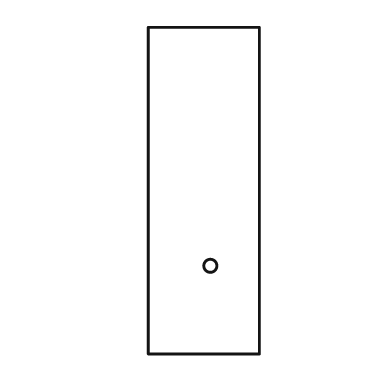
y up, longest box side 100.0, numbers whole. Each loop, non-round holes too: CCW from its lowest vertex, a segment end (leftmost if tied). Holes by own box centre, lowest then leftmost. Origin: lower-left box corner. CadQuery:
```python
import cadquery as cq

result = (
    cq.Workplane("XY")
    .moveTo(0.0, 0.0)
    .lineTo(34.0, 0.0)
    .lineTo(34.0, 100.0)
    .lineTo(0.0, 100.0)
    .close()
    .moveTo(19.0, 27.0)
    .circle(2.0)
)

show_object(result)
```